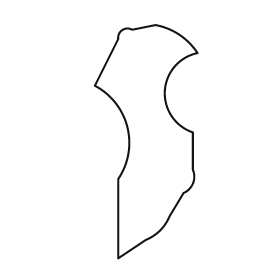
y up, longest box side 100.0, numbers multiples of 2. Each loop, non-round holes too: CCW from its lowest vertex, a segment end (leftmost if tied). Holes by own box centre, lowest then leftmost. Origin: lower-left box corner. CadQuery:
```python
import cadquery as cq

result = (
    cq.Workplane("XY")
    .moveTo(10.0, 0.0)
    .lineTo(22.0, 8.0)
    .threePointArc((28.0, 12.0), (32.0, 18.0))
    .lineTo(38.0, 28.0)
    .threePointArc((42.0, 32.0), (42.0, 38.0))
    .lineTo(42.0, 54.0)
    .threePointArc((30.0, 72.0), (44.0, 88.0))
    .threePointArc((36.0, 96.0), (26.0, 100.0))
    .lineTo(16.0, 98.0)
    .threePointArc((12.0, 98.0), (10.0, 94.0))
    .lineTo(0.0, 74.0)
    .threePointArc((14.0, 56.0), (10.0, 34.0))
    .close()
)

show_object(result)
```